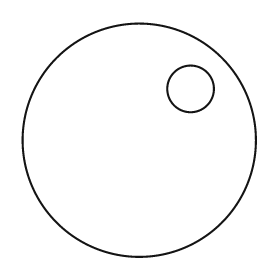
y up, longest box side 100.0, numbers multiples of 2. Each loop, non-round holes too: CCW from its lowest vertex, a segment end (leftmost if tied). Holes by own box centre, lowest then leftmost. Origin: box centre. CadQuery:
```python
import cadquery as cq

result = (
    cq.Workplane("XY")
    .moveTo(0.0, 0.0)
    .circle(50.0)
    .moveTo(22.0, 22.0)
    .circle(10.0)
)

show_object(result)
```